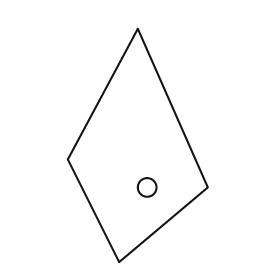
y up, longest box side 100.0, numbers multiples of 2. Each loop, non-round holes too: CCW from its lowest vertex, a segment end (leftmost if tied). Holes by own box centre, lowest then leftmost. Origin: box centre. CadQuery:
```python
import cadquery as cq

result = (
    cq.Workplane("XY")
    .moveTo(-8.0, -50.0)
    .lineTo(30.0, -18.0)
    .lineTo(0.0, 50.0)
    .lineTo(-30.0, -6.0)
    .close()
    .moveTo(4.0, -18.0)
    .circle(4.0)
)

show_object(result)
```